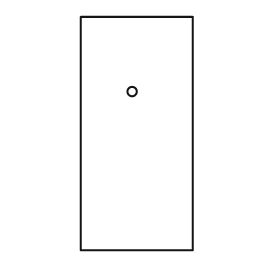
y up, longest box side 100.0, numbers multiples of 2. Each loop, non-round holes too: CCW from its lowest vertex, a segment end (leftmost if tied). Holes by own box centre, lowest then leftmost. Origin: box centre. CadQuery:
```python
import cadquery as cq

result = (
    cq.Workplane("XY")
    .moveTo(-24.0, -50.0)
    .lineTo(24.0, -50.0)
    .lineTo(24.0, 50.0)
    .lineTo(-24.0, 50.0)
    .close()
    .moveTo(-2.0, 18.0)
    .circle(2.0)
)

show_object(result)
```